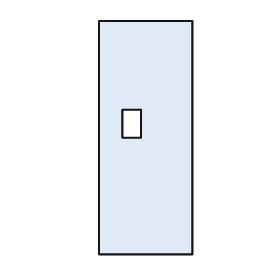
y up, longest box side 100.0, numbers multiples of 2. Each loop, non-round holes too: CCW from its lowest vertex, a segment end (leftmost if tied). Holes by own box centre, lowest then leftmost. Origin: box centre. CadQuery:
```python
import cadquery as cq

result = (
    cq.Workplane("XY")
    .moveTo(-20.0, -50.0)
    .lineTo(20.0, -50.0)
    .lineTo(20.0, 50.0)
    .lineTo(-20.0, 50.0)
    .close()
    .moveTo(-10.0, 0.0)
    .lineTo(-2.0, 0.0)
    .lineTo(-2.0, 12.0)
    .lineTo(-10.0, 12.0)
    .close()
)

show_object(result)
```